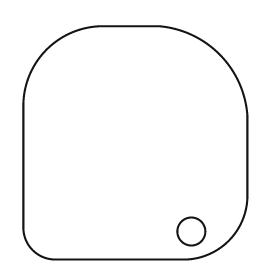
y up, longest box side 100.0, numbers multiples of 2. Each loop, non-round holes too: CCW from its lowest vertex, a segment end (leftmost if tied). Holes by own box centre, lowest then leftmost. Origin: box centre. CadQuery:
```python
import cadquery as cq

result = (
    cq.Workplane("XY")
    .moveTo(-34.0, -50.0)
    .lineTo(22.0, -50.0)
    .threePointArc((40.0, -42.0), (48.0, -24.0))
    .lineTo(48.0, 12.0)
    .threePointArc((36.0, 38.0), (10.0, 50.0))
    .lineTo(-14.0, 50.0)
    .threePointArc((-38.0, 40.0), (-48.0, 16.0))
    .lineTo(-48.0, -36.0)
    .threePointArc((-44.0, -46.0), (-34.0, -50.0))
    .close()
    .moveTo(24.0, -38.0)
    .circle(6.0)
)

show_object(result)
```